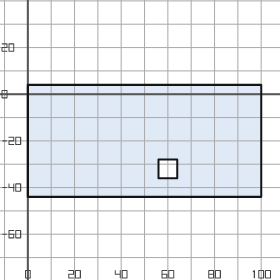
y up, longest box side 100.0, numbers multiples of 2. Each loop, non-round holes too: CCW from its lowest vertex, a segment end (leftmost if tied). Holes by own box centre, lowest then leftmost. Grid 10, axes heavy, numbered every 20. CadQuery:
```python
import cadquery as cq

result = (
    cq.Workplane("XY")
    .moveTo(0.0, -44.0)
    .lineTo(100.0, -44.0)
    .lineTo(100.0, 4.0)
    .lineTo(0.0, 4.0)
    .close()
    .moveTo(56.0, -36.0)
    .lineTo(64.0, -36.0)
    .lineTo(64.0, -28.0)
    .lineTo(56.0, -28.0)
    .close()
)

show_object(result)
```